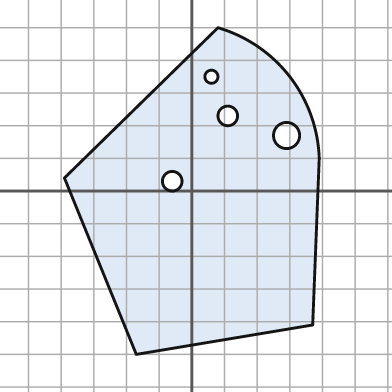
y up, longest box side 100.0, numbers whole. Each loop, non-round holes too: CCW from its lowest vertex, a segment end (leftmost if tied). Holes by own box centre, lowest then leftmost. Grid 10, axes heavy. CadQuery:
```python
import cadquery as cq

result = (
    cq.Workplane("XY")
    .moveTo(-17.0, -50.0)
    .lineTo(37.0, -41.0)
    .lineTo(39.0, 10.0)
    .threePointArc((30.0, 35.0), (8.0, 50.0))
    .lineTo(-39.0, 4.0)
    .close()
    .moveTo(-6.0, 3.0)
    .circle(3.0)
    .moveTo(29.0, 17.0)
    .circle(4.0)
    .moveTo(11.0, 23.0)
    .circle(3.0)
    .moveTo(6.0, 35.0)
    .circle(2.0)
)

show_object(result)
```